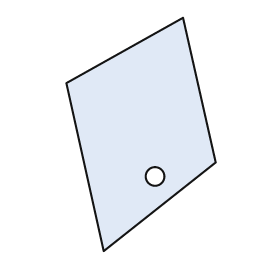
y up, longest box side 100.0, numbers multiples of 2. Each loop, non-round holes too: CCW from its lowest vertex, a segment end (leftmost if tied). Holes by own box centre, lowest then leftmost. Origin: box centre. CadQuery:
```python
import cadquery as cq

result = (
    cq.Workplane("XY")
    .moveTo(-16.0, -50.0)
    .lineTo(32.0, -12.0)
    .lineTo(18.0, 50.0)
    .lineTo(-32.0, 22.0)
    .close()
    .moveTo(6.0, -18.0)
    .circle(4.0)
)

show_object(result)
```